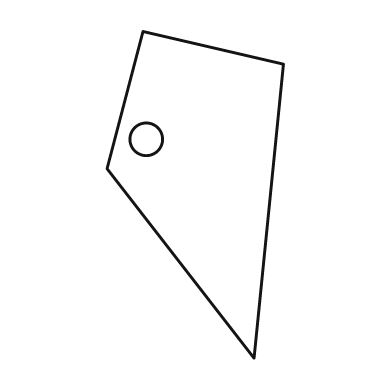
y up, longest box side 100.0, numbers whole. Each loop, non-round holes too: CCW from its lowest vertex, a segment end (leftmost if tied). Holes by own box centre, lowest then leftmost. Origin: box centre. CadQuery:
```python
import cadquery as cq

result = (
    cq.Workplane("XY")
    .moveTo(18.0, -50.0)
    .lineTo(27.0, 40.0)
    .lineTo(-16.0, 50.0)
    .lineTo(-27.0, 8.0)
    .close()
    .moveTo(-15.0, 17.0)
    .circle(5.0)
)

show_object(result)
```